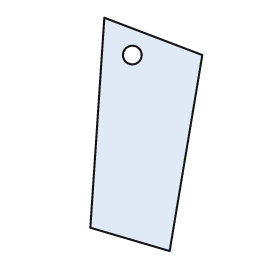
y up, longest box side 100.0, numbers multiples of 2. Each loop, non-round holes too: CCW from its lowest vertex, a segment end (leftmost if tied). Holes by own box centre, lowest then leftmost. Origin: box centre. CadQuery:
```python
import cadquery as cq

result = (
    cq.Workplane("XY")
    .moveTo(10.0, -50.0)
    .lineTo(24.0, 34.0)
    .lineTo(-18.0, 50.0)
    .lineTo(-24.0, -40.0)
    .close()
    .moveTo(-6.0, 34.0)
    .circle(4.0)
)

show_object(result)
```